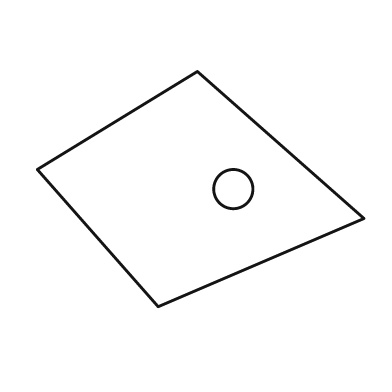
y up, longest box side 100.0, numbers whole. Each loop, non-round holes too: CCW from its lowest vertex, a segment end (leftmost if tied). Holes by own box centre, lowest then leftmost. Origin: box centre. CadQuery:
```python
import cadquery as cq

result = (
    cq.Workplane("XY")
    .moveTo(-13.0, -36.0)
    .lineTo(50.0, -9.0)
    .lineTo(-1.0, 36.0)
    .lineTo(-50.0, 6.0)
    .close()
    .moveTo(10.0, 0.0)
    .circle(6.0)
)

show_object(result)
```